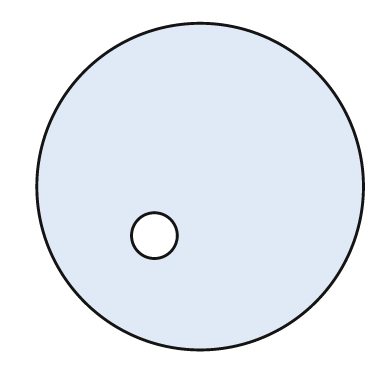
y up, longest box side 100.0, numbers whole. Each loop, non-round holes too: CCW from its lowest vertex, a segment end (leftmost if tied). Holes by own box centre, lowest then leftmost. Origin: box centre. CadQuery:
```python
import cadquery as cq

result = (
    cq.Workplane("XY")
    .moveTo(0.0, 0.0)
    .circle(50.0)
    .moveTo(-14.0, -15.0)
    .circle(7.0)
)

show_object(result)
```